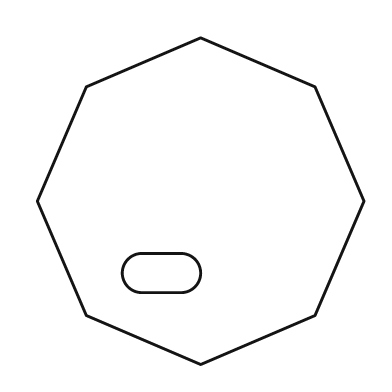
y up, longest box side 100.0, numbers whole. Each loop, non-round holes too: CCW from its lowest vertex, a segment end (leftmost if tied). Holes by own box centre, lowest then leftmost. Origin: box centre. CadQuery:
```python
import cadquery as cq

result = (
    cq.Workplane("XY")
    .moveTo(0.0, -50.0)
    .lineTo(35.0, -35.0)
    .lineTo(50.0, 0.0)
    .lineTo(35.0, 35.0)
    .lineTo(0.0, 50.0)
    .lineTo(-35.0, 35.0)
    .lineTo(-50.0, 0.0)
    .lineTo(-35.0, -35.0)
    .close()
    .moveTo(-18.0, -28.0)
    .lineTo(-6.0, -28.0)
    .threePointArc((0.0, -22.0), (-6.0, -16.0))
    .lineTo(-18.0, -16.0)
    .threePointArc((-24.0, -22.0), (-18.0, -28.0))
    .close()
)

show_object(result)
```